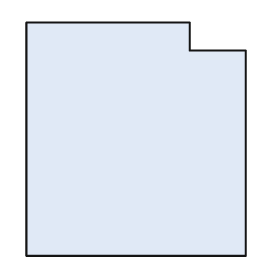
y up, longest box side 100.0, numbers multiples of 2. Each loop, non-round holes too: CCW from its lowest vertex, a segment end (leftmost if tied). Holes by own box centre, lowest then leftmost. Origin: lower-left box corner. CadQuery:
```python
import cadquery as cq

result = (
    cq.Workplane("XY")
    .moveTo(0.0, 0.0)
    .lineTo(94.0, 0.0)
    .lineTo(94.0, 88.0)
    .lineTo(70.0, 88.0)
    .lineTo(70.0, 100.0)
    .lineTo(0.0, 100.0)
    .close()
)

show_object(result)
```